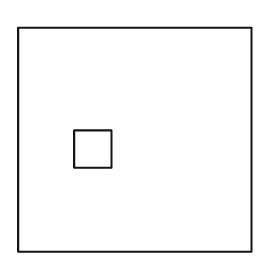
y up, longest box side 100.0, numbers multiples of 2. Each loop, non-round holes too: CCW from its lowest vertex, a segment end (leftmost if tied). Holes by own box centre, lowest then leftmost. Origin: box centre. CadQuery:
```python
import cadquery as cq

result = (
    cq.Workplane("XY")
    .moveTo(-50.0, -48.0)
    .lineTo(50.0, -48.0)
    .lineTo(50.0, 48.0)
    .lineTo(-50.0, 48.0)
    .close()
    .moveTo(-26.0, -12.0)
    .lineTo(-10.0, -12.0)
    .lineTo(-10.0, 4.0)
    .lineTo(-26.0, 4.0)
    .close()
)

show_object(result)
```